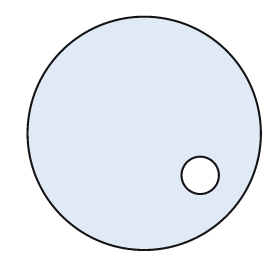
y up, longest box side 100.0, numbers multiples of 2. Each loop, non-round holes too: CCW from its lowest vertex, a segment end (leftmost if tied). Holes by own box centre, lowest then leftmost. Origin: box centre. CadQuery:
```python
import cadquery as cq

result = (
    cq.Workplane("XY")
    .moveTo(0.0, 0.0)
    .circle(50.0)
    .moveTo(24.0, -18.0)
    .circle(8.0)
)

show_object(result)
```